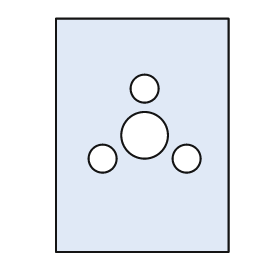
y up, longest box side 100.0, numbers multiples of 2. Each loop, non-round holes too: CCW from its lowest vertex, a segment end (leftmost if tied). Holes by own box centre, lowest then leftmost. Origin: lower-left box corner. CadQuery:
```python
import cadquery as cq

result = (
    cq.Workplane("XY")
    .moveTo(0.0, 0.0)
    .lineTo(74.0, 0.0)
    .lineTo(74.0, 100.0)
    .lineTo(0.0, 100.0)
    .close()
    .moveTo(20.0, 40.0)
    .circle(6.0)
    .moveTo(56.0, 40.0)
    .circle(6.0)
    .moveTo(38.0, 50.0)
    .circle(10.0)
    .moveTo(38.0, 70.0)
    .circle(6.0)
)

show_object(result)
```